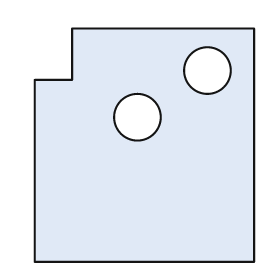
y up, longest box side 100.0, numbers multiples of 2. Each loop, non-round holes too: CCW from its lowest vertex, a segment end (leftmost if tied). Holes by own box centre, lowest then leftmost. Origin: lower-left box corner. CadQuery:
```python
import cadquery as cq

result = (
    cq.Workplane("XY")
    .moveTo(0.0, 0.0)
    .lineTo(94.0, 0.0)
    .lineTo(94.0, 100.0)
    .lineTo(16.0, 100.0)
    .lineTo(16.0, 78.0)
    .lineTo(0.0, 78.0)
    .close()
    .moveTo(44.0, 62.0)
    .circle(10.0)
    .moveTo(74.0, 82.0)
    .circle(10.0)
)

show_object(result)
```